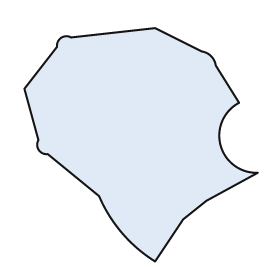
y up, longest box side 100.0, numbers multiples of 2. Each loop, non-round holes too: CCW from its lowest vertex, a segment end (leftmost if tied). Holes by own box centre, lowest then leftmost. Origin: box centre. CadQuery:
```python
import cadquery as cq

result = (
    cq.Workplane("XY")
    .moveTo(6.0, -50.0)
    .lineTo(18.0, -32.0)
    .lineTo(28.0, -24.0)
    .lineTo(50.0, -12.0)
    .threePointArc((34.0, 0.0), (42.0, 18.0))
    .lineTo(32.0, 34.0)
    .threePointArc((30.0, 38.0), (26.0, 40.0))
    .lineTo(6.0, 50.0)
    .lineTo(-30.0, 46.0)
    .threePointArc((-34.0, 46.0), (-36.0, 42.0))
    .lineTo(-50.0, 24.0)
    .lineTo(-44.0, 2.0)
    .threePointArc((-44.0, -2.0), (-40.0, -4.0))
    .lineTo(-18.0, -22.0)
    .threePointArc((-8.0, -38.0), (6.0, -50.0))
    .close()
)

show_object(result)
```